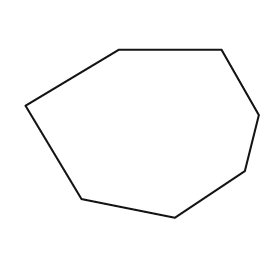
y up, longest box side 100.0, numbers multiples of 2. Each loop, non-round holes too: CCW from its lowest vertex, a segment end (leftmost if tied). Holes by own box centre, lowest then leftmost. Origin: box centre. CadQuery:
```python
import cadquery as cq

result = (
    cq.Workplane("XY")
    .moveTo(14.0, -36.0)
    .lineTo(44.0, -16.0)
    .lineTo(50.0, 8.0)
    .lineTo(34.0, 36.0)
    .lineTo(-10.0, 36.0)
    .lineTo(-50.0, 12.0)
    .lineTo(-26.0, -28.0)
    .close()
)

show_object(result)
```